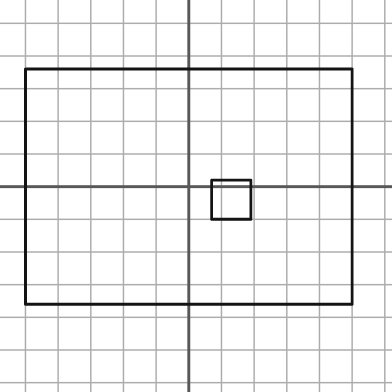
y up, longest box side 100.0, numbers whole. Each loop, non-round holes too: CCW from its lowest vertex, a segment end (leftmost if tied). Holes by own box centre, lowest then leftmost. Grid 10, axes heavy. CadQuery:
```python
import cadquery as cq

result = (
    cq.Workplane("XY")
    .moveTo(-50.0, -36.0)
    .lineTo(50.0, -36.0)
    .lineTo(50.0, 36.0)
    .lineTo(-50.0, 36.0)
    .close()
    .moveTo(7.0, -10.0)
    .lineTo(19.0, -10.0)
    .lineTo(19.0, 2.0)
    .lineTo(7.0, 2.0)
    .close()
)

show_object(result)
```